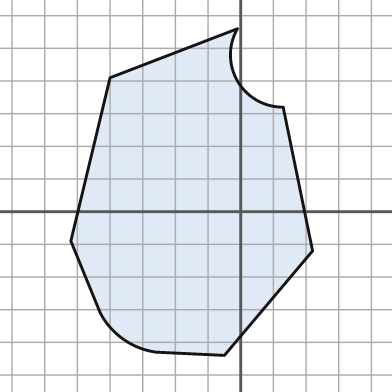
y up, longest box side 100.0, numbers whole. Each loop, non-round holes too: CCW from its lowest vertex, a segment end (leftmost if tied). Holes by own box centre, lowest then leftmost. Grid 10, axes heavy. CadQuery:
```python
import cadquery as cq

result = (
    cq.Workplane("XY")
    .moveTo(-5.0, -44.0)
    .lineTo(22.0, -12.0)
    .lineTo(13.0, 32.0)
    .threePointArc((-1.0, 40.0), (-1.0, 56.0))
    .lineTo(-40.0, 41.0)
    .lineTo(-52.0, -9.0)
    .lineTo(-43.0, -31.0)
    .threePointArc((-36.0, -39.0), (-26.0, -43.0))
    .close()
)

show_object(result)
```